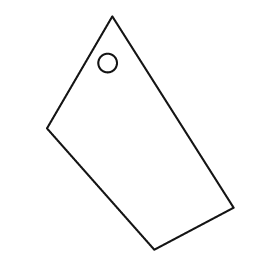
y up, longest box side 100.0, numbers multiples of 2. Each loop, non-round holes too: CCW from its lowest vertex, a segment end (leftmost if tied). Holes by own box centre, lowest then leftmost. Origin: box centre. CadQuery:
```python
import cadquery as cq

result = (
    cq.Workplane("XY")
    .moveTo(6.0, -50.0)
    .lineTo(40.0, -32.0)
    .lineTo(-12.0, 50.0)
    .lineTo(-40.0, 2.0)
    .close()
    .moveTo(-14.0, 30.0)
    .circle(4.0)
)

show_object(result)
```